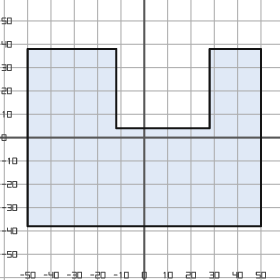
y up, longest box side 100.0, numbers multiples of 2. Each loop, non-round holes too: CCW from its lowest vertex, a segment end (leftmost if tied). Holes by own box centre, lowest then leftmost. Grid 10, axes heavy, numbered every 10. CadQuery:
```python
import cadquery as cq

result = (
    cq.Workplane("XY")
    .moveTo(-50.0, -38.0)
    .lineTo(50.0, -38.0)
    .lineTo(50.0, 38.0)
    .lineTo(28.0, 38.0)
    .lineTo(28.0, 4.0)
    .lineTo(-12.0, 4.0)
    .lineTo(-12.0, 38.0)
    .lineTo(-50.0, 38.0)
    .close()
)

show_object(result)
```